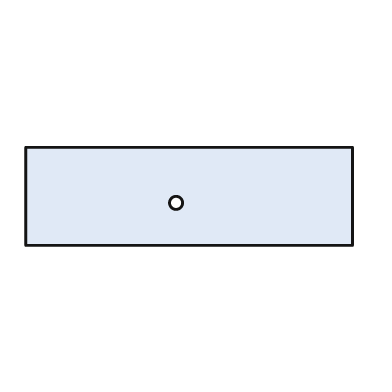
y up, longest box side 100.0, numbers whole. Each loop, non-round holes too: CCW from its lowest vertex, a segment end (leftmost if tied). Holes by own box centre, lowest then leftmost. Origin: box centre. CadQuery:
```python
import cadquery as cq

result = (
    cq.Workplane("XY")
    .moveTo(-50.0, -15.0)
    .lineTo(50.0, -15.0)
    .lineTo(50.0, 15.0)
    .lineTo(-50.0, 15.0)
    .close()
    .moveTo(-4.0, -2.0)
    .circle(2.0)
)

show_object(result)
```